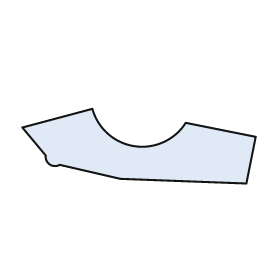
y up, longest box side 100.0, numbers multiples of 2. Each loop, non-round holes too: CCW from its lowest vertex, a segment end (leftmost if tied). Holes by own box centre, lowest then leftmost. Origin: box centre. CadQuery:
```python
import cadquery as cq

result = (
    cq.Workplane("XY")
    .moveTo(46.0, -16.0)
    .lineTo(50.0, 4.0)
    .lineTo(20.0, 10.0)
    .threePointArc((-2.0, 0.0), (-20.0, 16.0))
    .lineTo(-50.0, 8.0)
    .lineTo(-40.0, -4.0)
    .threePointArc((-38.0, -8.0), (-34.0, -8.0))
    .lineTo(-8.0, -14.0)
    .close()
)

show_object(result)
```